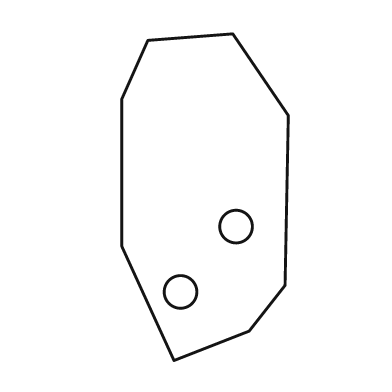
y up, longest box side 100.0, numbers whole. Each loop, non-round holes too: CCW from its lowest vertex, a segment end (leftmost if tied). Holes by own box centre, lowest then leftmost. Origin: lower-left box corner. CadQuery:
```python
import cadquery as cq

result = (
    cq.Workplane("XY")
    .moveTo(16.0, 0.0)
    .lineTo(39.0, 9.0)
    .lineTo(50.0, 23.0)
    .lineTo(51.0, 75.0)
    .lineTo(34.0, 100.0)
    .lineTo(8.0, 98.0)
    .lineTo(0.0, 80.0)
    .lineTo(0.0, 35.0)
    .close()
    .moveTo(18.0, 21.0)
    .circle(5.0)
    .moveTo(35.0, 41.0)
    .circle(5.0)
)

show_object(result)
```